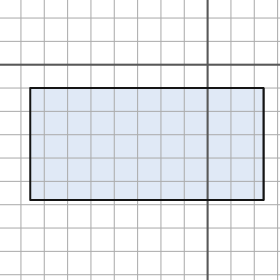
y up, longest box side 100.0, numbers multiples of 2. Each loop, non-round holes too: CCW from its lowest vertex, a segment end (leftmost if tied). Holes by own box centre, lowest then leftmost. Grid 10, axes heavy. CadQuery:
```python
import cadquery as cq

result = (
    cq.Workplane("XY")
    .moveTo(-76.0, -58.0)
    .lineTo(24.0, -58.0)
    .lineTo(24.0, -10.0)
    .lineTo(-76.0, -10.0)
    .close()
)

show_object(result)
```